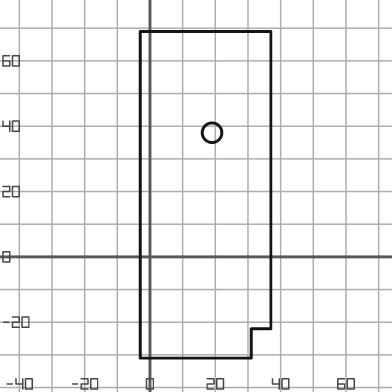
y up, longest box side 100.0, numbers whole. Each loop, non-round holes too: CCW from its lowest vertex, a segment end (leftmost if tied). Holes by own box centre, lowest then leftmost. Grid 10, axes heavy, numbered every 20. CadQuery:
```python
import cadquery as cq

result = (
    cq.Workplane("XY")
    .moveTo(-3.0, -31.0)
    .lineTo(31.0, -31.0)
    .lineTo(31.0, -22.0)
    .lineTo(37.0, -22.0)
    .lineTo(37.0, 69.0)
    .lineTo(-3.0, 69.0)
    .close()
    .moveTo(19.0, 38.0)
    .circle(3.0)
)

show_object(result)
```